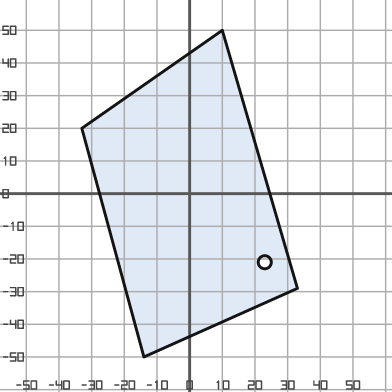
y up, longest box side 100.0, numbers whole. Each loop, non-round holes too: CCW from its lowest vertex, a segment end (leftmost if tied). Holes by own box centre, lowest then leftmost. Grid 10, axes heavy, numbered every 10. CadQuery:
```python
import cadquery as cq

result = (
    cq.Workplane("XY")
    .moveTo(-14.0, -50.0)
    .lineTo(33.0, -29.0)
    .lineTo(10.0, 50.0)
    .lineTo(-33.0, 20.0)
    .close()
    .moveTo(23.0, -21.0)
    .circle(2.0)
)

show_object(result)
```